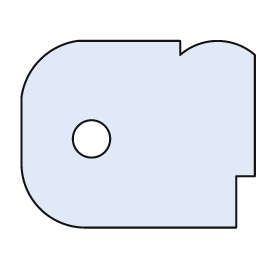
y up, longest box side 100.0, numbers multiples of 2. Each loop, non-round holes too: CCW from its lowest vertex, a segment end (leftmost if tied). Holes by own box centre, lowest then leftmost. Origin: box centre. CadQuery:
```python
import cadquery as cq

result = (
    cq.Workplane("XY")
    .moveTo(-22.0, -40.0)
    .lineTo(42.0, -40.0)
    .lineTo(42.0, -18.0)
    .lineTo(50.0, -18.0)
    .lineTo(50.0, 34.0)
    .threePointArc((34.0, 40.0), (18.0, 34.0))
    .lineTo(18.0, 40.0)
    .lineTo(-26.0, 40.0)
    .threePointArc((-42.0, 32.0), (-50.0, 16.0))
    .lineTo(-50.0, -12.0)
    .threePointArc((-42.0, -32.0), (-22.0, -40.0))
    .close()
    .moveTo(-20.0, -2.0)
    .circle(8.0)
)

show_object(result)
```